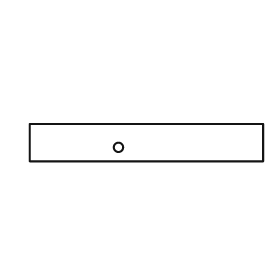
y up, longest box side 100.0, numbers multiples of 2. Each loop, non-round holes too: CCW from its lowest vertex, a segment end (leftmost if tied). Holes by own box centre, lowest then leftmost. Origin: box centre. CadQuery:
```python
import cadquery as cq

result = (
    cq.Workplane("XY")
    .moveTo(-50.0, -8.0)
    .lineTo(50.0, -8.0)
    .lineTo(50.0, 8.0)
    .lineTo(-50.0, 8.0)
    .close()
    .moveTo(-12.0, -2.0)
    .circle(2.0)
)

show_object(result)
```